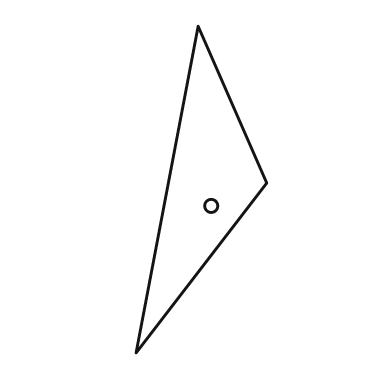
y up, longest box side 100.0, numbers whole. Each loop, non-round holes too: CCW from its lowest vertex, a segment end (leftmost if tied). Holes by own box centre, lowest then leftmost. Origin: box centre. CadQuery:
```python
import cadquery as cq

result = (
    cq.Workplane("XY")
    .moveTo(-20.0, -50.0)
    .lineTo(20.0, 2.0)
    .lineTo(-1.0, 50.0)
    .close()
    .moveTo(3.0, -5.0)
    .circle(2.0)
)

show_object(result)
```